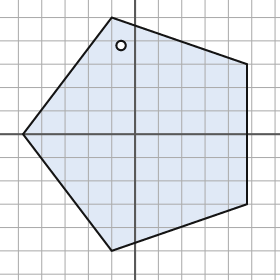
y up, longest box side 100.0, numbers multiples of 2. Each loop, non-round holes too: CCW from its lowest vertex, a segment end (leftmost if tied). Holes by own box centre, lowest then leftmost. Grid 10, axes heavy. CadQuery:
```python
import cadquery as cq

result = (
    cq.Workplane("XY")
    .moveTo(-10.0, -50.0)
    .lineTo(48.0, -30.0)
    .lineTo(48.0, 30.0)
    .lineTo(-10.0, 50.0)
    .lineTo(-48.0, 0.0)
    .close()
    .moveTo(-6.0, 38.0)
    .circle(2.0)
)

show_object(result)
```